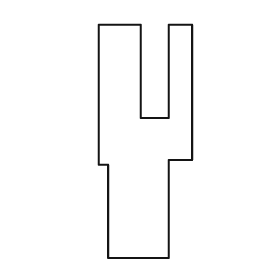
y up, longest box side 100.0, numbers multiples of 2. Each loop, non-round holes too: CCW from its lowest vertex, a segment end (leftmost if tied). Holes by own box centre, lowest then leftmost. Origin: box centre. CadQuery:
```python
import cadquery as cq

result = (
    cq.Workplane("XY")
    .moveTo(-16.0, -50.0)
    .lineTo(10.0, -50.0)
    .lineTo(10.0, -8.0)
    .lineTo(20.0, -8.0)
    .lineTo(20.0, 50.0)
    .lineTo(10.0, 50.0)
    .lineTo(10.0, 10.0)
    .lineTo(-2.0, 10.0)
    .lineTo(-2.0, 50.0)
    .lineTo(-20.0, 50.0)
    .lineTo(-20.0, -10.0)
    .lineTo(-16.0, -10.0)
    .close()
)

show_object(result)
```